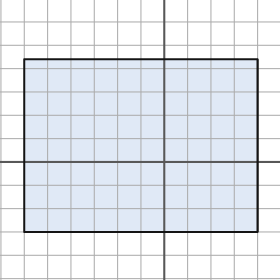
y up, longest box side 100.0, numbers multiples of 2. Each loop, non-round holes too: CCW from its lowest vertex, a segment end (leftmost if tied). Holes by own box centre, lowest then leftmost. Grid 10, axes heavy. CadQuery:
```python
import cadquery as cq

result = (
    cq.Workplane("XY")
    .moveTo(-60.0, -30.0)
    .lineTo(40.0, -30.0)
    .lineTo(40.0, 44.0)
    .lineTo(-60.0, 44.0)
    .close()
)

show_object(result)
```